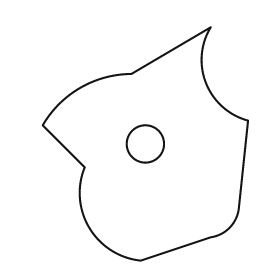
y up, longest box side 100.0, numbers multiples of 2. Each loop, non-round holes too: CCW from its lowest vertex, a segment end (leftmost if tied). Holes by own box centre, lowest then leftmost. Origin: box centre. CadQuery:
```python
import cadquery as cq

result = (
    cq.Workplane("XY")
    .moveTo(-2.0, -50.0)
    .lineTo(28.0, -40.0)
    .threePointArc((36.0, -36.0), (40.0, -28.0))
    .lineTo(44.0, 10.0)
    .threePointArc((26.0, 26.0), (28.0, 50.0))
    .lineTo(-6.0, 30.0)
    .threePointArc((-28.0, 24.0), (-44.0, 8.0))
    .lineTo(-26.0, -10.0)
    .threePointArc((-24.0, -36.0), (-2.0, -50.0))
    .close()
    .moveTo(0.0, 0.0)
    .circle(8.0)
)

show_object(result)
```